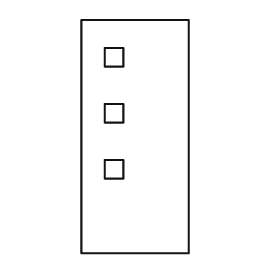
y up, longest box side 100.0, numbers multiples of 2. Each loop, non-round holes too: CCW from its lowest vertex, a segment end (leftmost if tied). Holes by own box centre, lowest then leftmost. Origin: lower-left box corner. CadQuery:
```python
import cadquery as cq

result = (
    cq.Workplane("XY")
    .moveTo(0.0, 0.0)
    .lineTo(46.0, 0.0)
    .lineTo(46.0, 100.0)
    .lineTo(0.0, 100.0)
    .close()
    .moveTo(10.0, 32.0)
    .lineTo(18.0, 32.0)
    .lineTo(18.0, 40.0)
    .lineTo(10.0, 40.0)
    .close()
    .moveTo(10.0, 56.0)
    .lineTo(18.0, 56.0)
    .lineTo(18.0, 64.0)
    .lineTo(10.0, 64.0)
    .close()
    .moveTo(10.0, 80.0)
    .lineTo(18.0, 80.0)
    .lineTo(18.0, 88.0)
    .lineTo(10.0, 88.0)
    .close()
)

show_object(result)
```